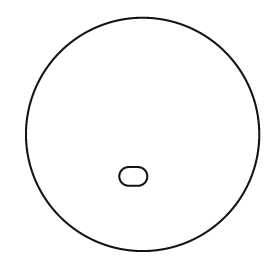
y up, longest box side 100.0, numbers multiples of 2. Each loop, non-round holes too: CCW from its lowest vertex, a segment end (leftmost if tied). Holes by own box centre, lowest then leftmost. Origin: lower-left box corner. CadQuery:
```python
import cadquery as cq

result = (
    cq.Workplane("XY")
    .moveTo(50.0, 50.0)
    .circle(50.0)
    .moveTo(44.0, 28.0)
    .lineTo(48.0, 28.0)
    .threePointArc((52.0, 32.0), (48.0, 36.0))
    .lineTo(44.0, 36.0)
    .threePointArc((40.0, 32.0), (44.0, 28.0))
    .close()
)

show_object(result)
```